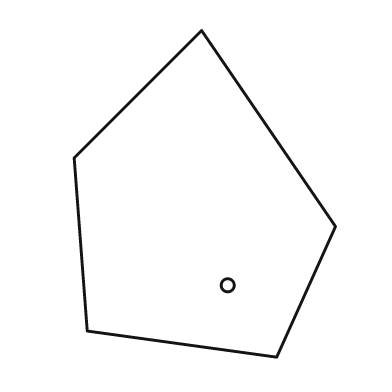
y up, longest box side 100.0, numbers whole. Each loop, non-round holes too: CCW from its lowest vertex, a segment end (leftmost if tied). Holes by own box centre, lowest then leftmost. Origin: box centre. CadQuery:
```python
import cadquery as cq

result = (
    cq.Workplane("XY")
    .moveTo(22.0, -50.0)
    .lineTo(40.0, -10.0)
    .lineTo(-1.0, 50.0)
    .lineTo(-40.0, 11.0)
    .lineTo(-36.0, -42.0)
    .close()
    .moveTo(7.0, -28.0)
    .circle(2.0)
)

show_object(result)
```